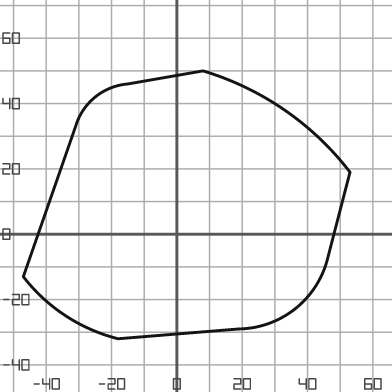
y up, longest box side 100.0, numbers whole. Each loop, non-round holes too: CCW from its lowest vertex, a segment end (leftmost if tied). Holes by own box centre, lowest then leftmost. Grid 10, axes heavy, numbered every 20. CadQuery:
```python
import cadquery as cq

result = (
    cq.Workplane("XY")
    .moveTo(-18.0, -32.0)
    .lineTo(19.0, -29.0)
    .threePointArc((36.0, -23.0), (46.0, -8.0))
    .lineTo(53.0, 19.0)
    .threePointArc((33.0, 38.0), (8.0, 50.0))
    .lineTo(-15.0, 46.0)
    .threePointArc((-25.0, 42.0), (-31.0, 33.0))
    .lineTo(-47.0, -13.0)
    .threePointArc((-34.0, -25.0), (-18.0, -32.0))
    .close()
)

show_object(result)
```